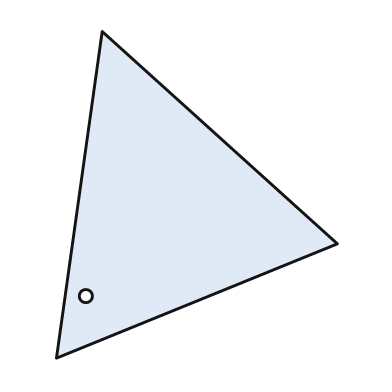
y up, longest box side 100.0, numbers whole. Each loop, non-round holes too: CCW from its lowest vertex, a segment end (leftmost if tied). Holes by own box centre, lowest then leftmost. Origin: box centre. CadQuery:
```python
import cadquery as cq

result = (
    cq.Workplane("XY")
    .moveTo(-43.0, -50.0)
    .lineTo(43.0, -15.0)
    .lineTo(-29.0, 50.0)
    .close()
    .moveTo(-34.0, -31.0)
    .circle(2.0)
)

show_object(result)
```